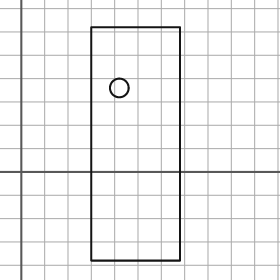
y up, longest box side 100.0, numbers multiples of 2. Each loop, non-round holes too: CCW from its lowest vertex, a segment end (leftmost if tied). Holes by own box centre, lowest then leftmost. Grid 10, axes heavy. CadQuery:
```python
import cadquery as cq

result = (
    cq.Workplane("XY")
    .moveTo(30.0, -38.0)
    .lineTo(68.0, -38.0)
    .lineTo(68.0, 62.0)
    .lineTo(30.0, 62.0)
    .close()
    .moveTo(42.0, 36.0)
    .circle(4.0)
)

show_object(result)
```